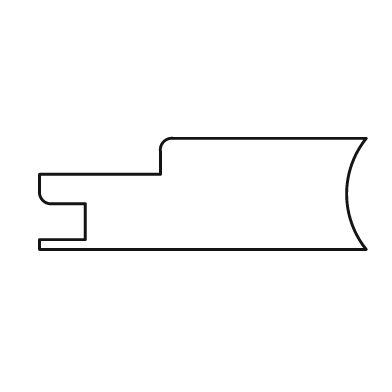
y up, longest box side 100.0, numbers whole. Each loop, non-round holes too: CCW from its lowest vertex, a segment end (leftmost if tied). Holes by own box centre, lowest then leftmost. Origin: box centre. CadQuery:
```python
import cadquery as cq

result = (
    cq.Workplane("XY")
    .moveTo(-50.0, -17.0)
    .lineTo(50.0, -17.0)
    .threePointArc((44.0, 0.0), (50.0, 17.0))
    .lineTo(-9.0, 17.0)
    .threePointArc((-12.0, 16.0), (-13.0, 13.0))
    .lineTo(-13.0, 6.0)
    .lineTo(-50.0, 6.0)
    .lineTo(-50.0, 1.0)
    .threePointArc((-49.0, -2.0), (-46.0, -3.0))
    .lineTo(-36.0, -3.0)
    .lineTo(-36.0, -14.0)
    .lineTo(-50.0, -14.0)
    .close()
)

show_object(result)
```